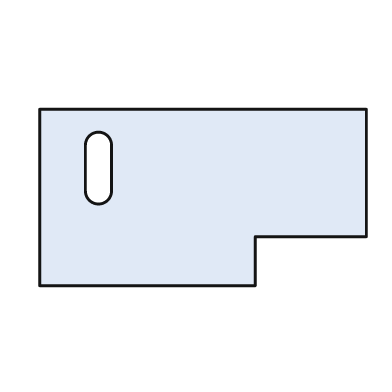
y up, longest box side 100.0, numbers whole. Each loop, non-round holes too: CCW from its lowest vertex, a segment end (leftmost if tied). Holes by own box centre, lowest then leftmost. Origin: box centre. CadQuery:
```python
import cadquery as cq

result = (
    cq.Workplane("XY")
    .moveTo(-50.0, -27.0)
    .lineTo(16.0, -27.0)
    .lineTo(16.0, -12.0)
    .lineTo(50.0, -12.0)
    .lineTo(50.0, 27.0)
    .lineTo(-50.0, 27.0)
    .close()
    .moveTo(-36.0, 2.0)
    .threePointArc((-32.0, -2.0), (-28.0, 2.0))
    .lineTo(-28.0, 16.0)
    .threePointArc((-32.0, 20.0), (-36.0, 16.0))
    .close()
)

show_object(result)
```